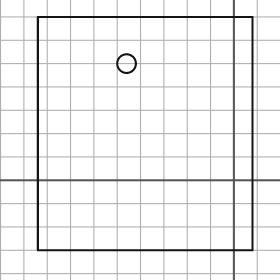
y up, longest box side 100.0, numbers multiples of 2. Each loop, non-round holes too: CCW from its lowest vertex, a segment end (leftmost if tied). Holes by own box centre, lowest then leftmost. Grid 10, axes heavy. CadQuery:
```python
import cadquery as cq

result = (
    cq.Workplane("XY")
    .moveTo(-84.0, -30.0)
    .lineTo(8.0, -30.0)
    .lineTo(8.0, 70.0)
    .lineTo(-84.0, 70.0)
    .close()
    .moveTo(-46.0, 50.0)
    .circle(4.0)
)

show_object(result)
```